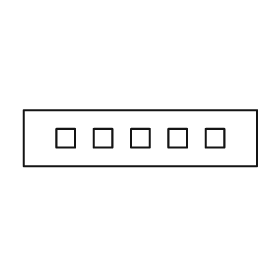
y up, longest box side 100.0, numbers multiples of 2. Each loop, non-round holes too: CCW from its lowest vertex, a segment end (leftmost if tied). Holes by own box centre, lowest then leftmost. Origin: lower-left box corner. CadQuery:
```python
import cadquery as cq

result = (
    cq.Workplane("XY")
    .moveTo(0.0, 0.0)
    .lineTo(100.0, 0.0)
    .lineTo(100.0, 24.0)
    .lineTo(0.0, 24.0)
    .close()
    .moveTo(14.0, 8.0)
    .lineTo(22.0, 8.0)
    .lineTo(22.0, 16.0)
    .lineTo(14.0, 16.0)
    .close()
    .moveTo(30.0, 8.0)
    .lineTo(38.0, 8.0)
    .lineTo(38.0, 16.0)
    .lineTo(30.0, 16.0)
    .close()
    .moveTo(46.0, 8.0)
    .lineTo(54.0, 8.0)
    .lineTo(54.0, 16.0)
    .lineTo(46.0, 16.0)
    .close()
    .moveTo(62.0, 8.0)
    .lineTo(70.0, 8.0)
    .lineTo(70.0, 16.0)
    .lineTo(62.0, 16.0)
    .close()
    .moveTo(78.0, 8.0)
    .lineTo(86.0, 8.0)
    .lineTo(86.0, 16.0)
    .lineTo(78.0, 16.0)
    .close()
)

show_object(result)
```